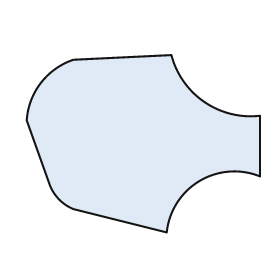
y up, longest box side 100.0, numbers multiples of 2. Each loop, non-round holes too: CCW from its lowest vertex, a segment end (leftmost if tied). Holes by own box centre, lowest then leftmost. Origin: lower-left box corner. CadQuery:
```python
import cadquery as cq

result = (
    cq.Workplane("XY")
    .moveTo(60.0, 0.0)
    .threePointArc((74.0, 22.0), (100.0, 24.0))
    .lineTo(100.0, 50.0)
    .threePointArc((76.0, 56.0), (62.0, 76.0))
    .lineTo(20.0, 74.0)
    .threePointArc((6.0, 64.0), (0.0, 48.0))
    .lineTo(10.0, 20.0)
    .threePointArc((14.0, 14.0), (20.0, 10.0))
    .close()
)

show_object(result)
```